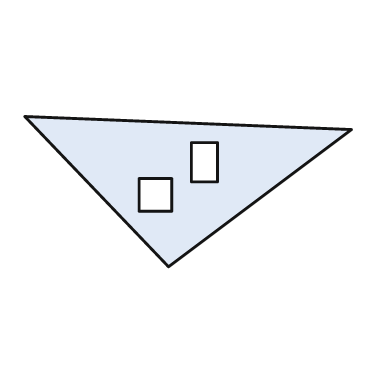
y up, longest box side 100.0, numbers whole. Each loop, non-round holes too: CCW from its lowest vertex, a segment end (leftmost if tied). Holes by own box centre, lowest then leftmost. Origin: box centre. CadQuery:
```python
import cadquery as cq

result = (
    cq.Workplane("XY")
    .moveTo(-6.0, -23.0)
    .lineTo(50.0, 19.0)
    .lineTo(-50.0, 23.0)
    .close()
    .moveTo(-15.0, -6.0)
    .lineTo(-5.0, -6.0)
    .lineTo(-5.0, 4.0)
    .lineTo(-15.0, 4.0)
    .close()
    .moveTo(1.0, 3.0)
    .lineTo(9.0, 3.0)
    .lineTo(9.0, 15.0)
    .lineTo(1.0, 15.0)
    .close()
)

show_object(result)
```